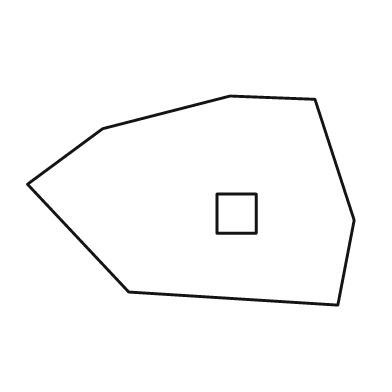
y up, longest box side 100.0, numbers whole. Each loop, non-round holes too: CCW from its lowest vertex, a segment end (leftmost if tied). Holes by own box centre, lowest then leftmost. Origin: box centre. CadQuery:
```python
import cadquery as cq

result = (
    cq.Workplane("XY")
    .moveTo(45.0, -32.0)
    .lineTo(50.0, -6.0)
    .lineTo(38.0, 31.0)
    .lineTo(12.0, 32.0)
    .lineTo(-27.0, 22.0)
    .lineTo(-50.0, 5.0)
    .lineTo(-19.0, -28.0)
    .close()
    .moveTo(8.0, -10.0)
    .lineTo(20.0, -10.0)
    .lineTo(20.0, 2.0)
    .lineTo(8.0, 2.0)
    .close()
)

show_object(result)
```